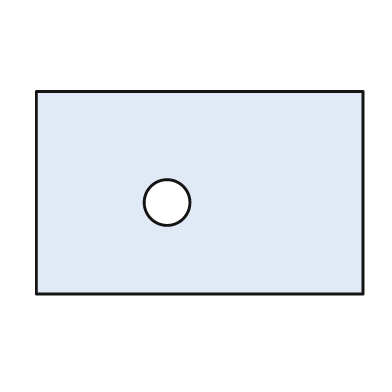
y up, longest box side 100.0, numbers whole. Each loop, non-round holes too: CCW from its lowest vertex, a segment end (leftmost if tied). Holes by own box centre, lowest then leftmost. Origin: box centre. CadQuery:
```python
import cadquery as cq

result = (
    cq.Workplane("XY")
    .moveTo(-50.0, -31.0)
    .lineTo(50.0, -31.0)
    .lineTo(50.0, 31.0)
    .lineTo(-50.0, 31.0)
    .close()
    .moveTo(-10.0, -3.0)
    .circle(7.0)
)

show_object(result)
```